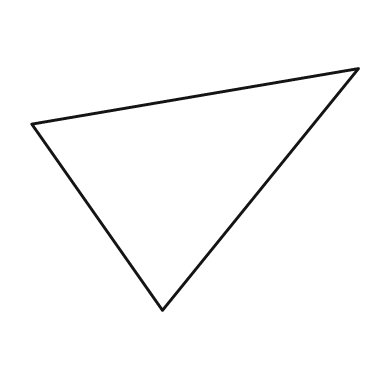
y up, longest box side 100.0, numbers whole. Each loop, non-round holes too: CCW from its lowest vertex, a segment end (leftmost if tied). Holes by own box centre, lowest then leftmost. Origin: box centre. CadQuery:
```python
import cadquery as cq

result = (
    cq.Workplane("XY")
    .moveTo(-10.0, -37.0)
    .lineTo(50.0, 37.0)
    .lineTo(-50.0, 20.0)
    .close()
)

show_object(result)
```